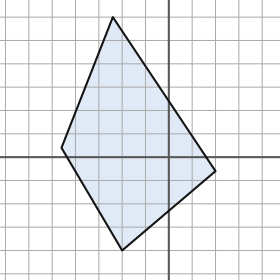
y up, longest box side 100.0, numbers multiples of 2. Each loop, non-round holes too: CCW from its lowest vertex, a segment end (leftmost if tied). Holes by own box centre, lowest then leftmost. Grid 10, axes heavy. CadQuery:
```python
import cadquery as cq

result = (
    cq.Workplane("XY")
    .moveTo(-20.0, -40.0)
    .lineTo(20.0, -6.0)
    .lineTo(-24.0, 60.0)
    .lineTo(-46.0, 4.0)
    .close()
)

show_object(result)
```